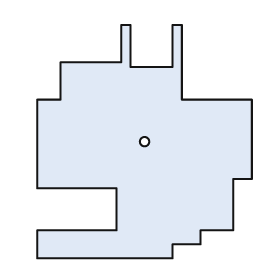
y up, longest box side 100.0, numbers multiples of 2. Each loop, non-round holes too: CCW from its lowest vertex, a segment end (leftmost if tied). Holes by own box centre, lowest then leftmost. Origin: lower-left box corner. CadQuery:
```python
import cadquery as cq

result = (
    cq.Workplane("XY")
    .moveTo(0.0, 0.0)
    .lineTo(58.0, 0.0)
    .lineTo(58.0, 6.0)
    .lineTo(70.0, 6.0)
    .lineTo(70.0, 12.0)
    .lineTo(84.0, 12.0)
    .lineTo(84.0, 34.0)
    .lineTo(92.0, 34.0)
    .lineTo(92.0, 68.0)
    .lineTo(62.0, 68.0)
    .lineTo(62.0, 100.0)
    .lineTo(58.0, 100.0)
    .lineTo(58.0, 82.0)
    .lineTo(40.0, 82.0)
    .lineTo(40.0, 100.0)
    .lineTo(36.0, 100.0)
    .lineTo(36.0, 84.0)
    .lineTo(10.0, 84.0)
    .lineTo(10.0, 68.0)
    .lineTo(0.0, 68.0)
    .lineTo(0.0, 30.0)
    .lineTo(34.0, 30.0)
    .lineTo(34.0, 12.0)
    .lineTo(0.0, 12.0)
    .close()
    .moveTo(46.0, 50.0)
    .circle(2.0)
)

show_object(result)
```